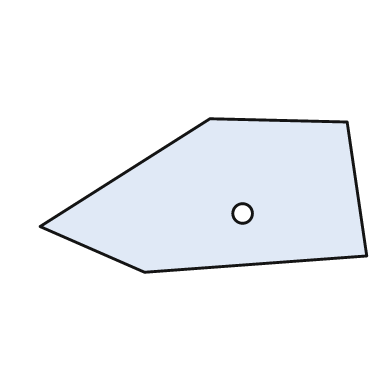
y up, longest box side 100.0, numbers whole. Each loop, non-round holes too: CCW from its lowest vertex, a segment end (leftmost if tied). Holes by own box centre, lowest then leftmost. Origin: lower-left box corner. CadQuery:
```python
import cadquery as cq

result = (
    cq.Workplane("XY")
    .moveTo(32.0, 0.0)
    .lineTo(100.0, 5.0)
    .lineTo(94.0, 46.0)
    .lineTo(52.0, 47.0)
    .lineTo(0.0, 14.0)
    .close()
    .moveTo(62.0, 18.0)
    .circle(3.0)
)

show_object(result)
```